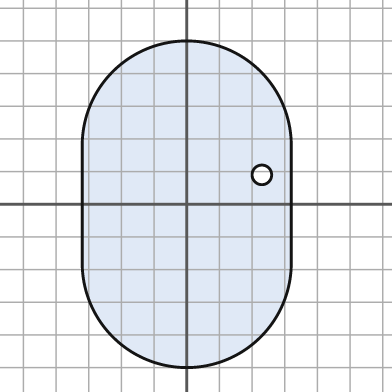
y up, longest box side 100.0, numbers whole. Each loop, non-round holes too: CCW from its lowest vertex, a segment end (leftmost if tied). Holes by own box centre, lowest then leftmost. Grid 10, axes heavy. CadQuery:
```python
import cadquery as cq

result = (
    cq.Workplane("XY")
    .moveTo(-32.0, -18.0)
    .threePointArc((0.0, -50.0), (32.0, -18.0))
    .lineTo(32.0, 18.0)
    .threePointArc((0.0, 50.0), (-32.0, 18.0))
    .close()
    .moveTo(23.0, 9.0)
    .circle(3.0)
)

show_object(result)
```